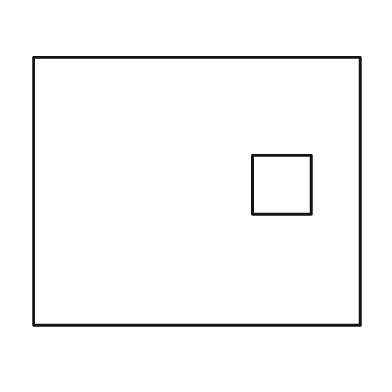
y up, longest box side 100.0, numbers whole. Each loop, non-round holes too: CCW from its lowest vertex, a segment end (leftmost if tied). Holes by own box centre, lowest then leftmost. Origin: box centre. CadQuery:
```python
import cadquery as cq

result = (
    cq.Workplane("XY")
    .moveTo(-50.0, -41.0)
    .lineTo(50.0, -41.0)
    .lineTo(50.0, 41.0)
    .lineTo(-50.0, 41.0)
    .close()
    .moveTo(17.0, -7.0)
    .lineTo(35.0, -7.0)
    .lineTo(35.0, 11.0)
    .lineTo(17.0, 11.0)
    .close()
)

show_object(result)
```